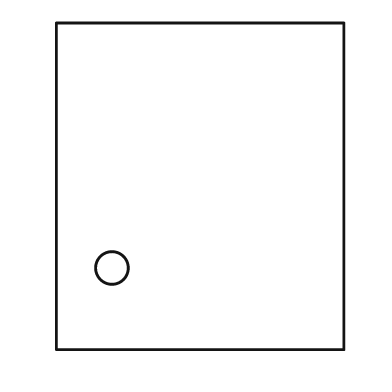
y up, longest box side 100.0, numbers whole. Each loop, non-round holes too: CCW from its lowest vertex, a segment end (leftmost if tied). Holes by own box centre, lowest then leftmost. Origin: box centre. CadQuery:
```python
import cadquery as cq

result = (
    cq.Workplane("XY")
    .moveTo(-44.0, -50.0)
    .lineTo(44.0, -50.0)
    .lineTo(44.0, 50.0)
    .lineTo(-44.0, 50.0)
    .close()
    .moveTo(-27.0, -25.0)
    .circle(5.0)
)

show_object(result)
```